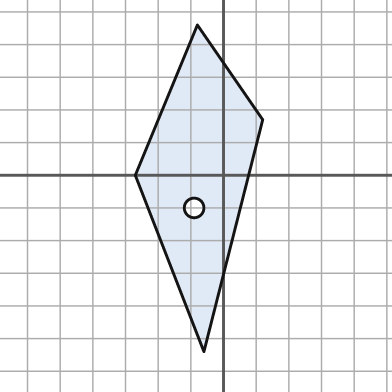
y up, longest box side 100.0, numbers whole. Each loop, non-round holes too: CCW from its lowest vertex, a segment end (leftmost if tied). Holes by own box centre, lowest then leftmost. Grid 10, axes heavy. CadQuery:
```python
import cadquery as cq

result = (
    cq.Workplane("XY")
    .moveTo(-6.0, -54.0)
    .lineTo(12.0, 17.0)
    .lineTo(-8.0, 46.0)
    .lineTo(-27.0, 0.0)
    .close()
    .moveTo(-9.0, -10.0)
    .circle(3.0)
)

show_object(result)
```